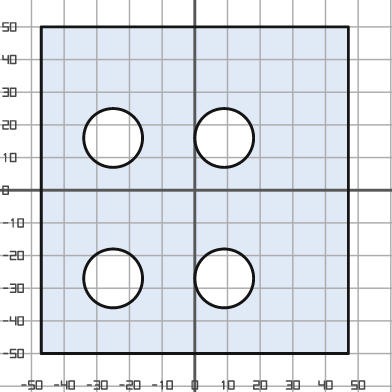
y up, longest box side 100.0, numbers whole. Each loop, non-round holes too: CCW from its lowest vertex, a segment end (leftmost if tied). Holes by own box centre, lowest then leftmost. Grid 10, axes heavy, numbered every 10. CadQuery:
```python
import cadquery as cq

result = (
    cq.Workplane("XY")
    .moveTo(-47.0, -50.0)
    .lineTo(47.0, -50.0)
    .lineTo(47.0, 50.0)
    .lineTo(-47.0, 50.0)
    .close()
    .moveTo(-25.0, -27.0)
    .circle(9.0)
    .moveTo(9.0, -27.0)
    .circle(9.0)
    .moveTo(-25.0, 16.0)
    .circle(9.0)
    .moveTo(9.0, 16.0)
    .circle(9.0)
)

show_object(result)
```